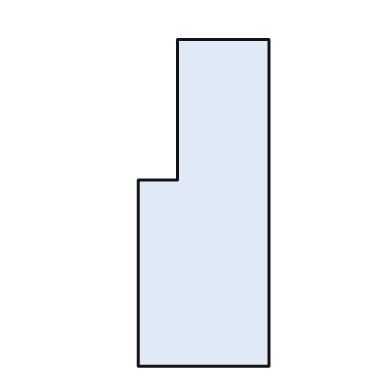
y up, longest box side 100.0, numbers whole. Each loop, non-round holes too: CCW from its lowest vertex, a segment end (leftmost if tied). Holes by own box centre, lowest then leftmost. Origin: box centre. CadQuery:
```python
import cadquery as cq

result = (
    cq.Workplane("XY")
    .moveTo(-20.0, -50.0)
    .lineTo(20.0, -50.0)
    .lineTo(20.0, 50.0)
    .lineTo(-8.0, 50.0)
    .lineTo(-8.0, 7.0)
    .lineTo(-20.0, 7.0)
    .close()
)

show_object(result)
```